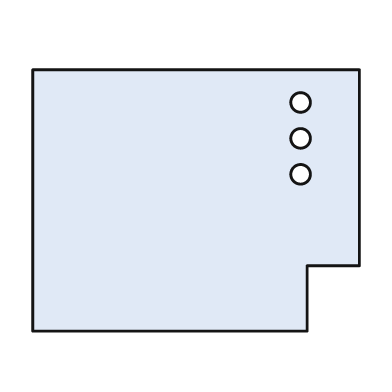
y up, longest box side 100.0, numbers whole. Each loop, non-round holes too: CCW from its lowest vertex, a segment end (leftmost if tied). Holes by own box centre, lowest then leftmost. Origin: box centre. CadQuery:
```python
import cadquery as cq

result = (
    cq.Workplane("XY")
    .moveTo(-50.0, -40.0)
    .lineTo(34.0, -40.0)
    .lineTo(34.0, -20.0)
    .lineTo(50.0, -20.0)
    .lineTo(50.0, 40.0)
    .lineTo(-50.0, 40.0)
    .close()
    .moveTo(32.0, 8.0)
    .circle(3.0)
    .moveTo(32.0, 19.0)
    .circle(3.0)
    .moveTo(32.0, 30.0)
    .circle(3.0)
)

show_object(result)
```